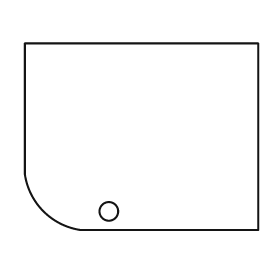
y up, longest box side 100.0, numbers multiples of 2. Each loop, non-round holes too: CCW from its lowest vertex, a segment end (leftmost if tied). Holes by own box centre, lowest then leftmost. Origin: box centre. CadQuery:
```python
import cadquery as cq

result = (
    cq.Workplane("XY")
    .moveTo(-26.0, -40.0)
    .lineTo(50.0, -40.0)
    .lineTo(50.0, 40.0)
    .lineTo(-50.0, 40.0)
    .lineTo(-50.0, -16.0)
    .threePointArc((-42.0, -32.0), (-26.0, -40.0))
    .close()
    .moveTo(-14.0, -32.0)
    .circle(4.0)
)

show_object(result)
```